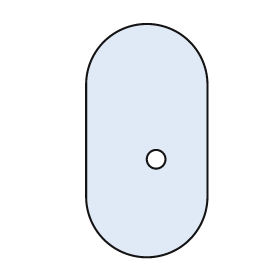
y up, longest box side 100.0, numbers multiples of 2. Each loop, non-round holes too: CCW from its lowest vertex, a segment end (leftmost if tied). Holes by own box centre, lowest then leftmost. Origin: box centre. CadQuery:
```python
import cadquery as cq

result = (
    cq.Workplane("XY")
    .moveTo(-26.0, -24.0)
    .threePointArc((0.0, -50.0), (26.0, -24.0))
    .lineTo(26.0, 24.0)
    .threePointArc((0.0, 50.0), (-26.0, 24.0))
    .close()
    .moveTo(4.0, -8.0)
    .circle(4.0)
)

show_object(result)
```